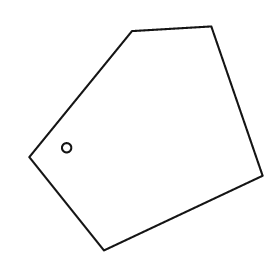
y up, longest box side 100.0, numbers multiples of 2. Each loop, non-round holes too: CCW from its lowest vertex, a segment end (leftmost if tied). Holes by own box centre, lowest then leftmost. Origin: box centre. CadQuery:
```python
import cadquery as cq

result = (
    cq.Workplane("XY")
    .moveTo(-18.0, -48.0)
    .lineTo(50.0, -16.0)
    .lineTo(28.0, 48.0)
    .lineTo(-6.0, 46.0)
    .lineTo(-50.0, -8.0)
    .close()
    .moveTo(-34.0, -4.0)
    .circle(2.0)
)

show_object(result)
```